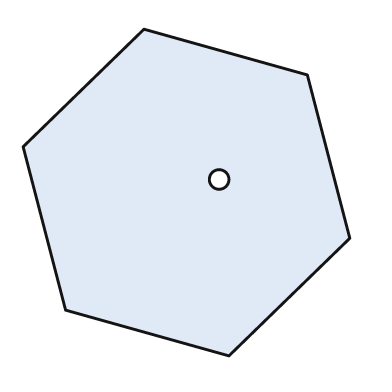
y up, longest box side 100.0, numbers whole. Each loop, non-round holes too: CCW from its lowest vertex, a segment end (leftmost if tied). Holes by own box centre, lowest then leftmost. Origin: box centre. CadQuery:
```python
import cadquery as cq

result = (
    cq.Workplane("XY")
    .moveTo(13.0, -50.0)
    .lineTo(50.0, -14.0)
    .lineTo(37.0, 36.0)
    .lineTo(-13.0, 50.0)
    .lineTo(-50.0, 14.0)
    .lineTo(-37.0, -36.0)
    .close()
    .moveTo(10.0, 4.0)
    .circle(3.0)
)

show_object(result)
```